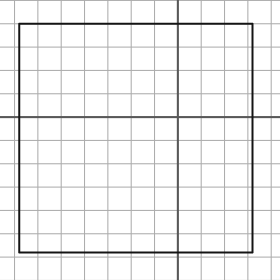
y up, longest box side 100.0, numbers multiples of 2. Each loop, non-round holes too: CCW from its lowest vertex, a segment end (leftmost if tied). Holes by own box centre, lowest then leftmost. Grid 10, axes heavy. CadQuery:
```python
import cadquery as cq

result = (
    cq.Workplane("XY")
    .moveTo(-68.0, -58.0)
    .lineTo(32.0, -58.0)
    .lineTo(32.0, 40.0)
    .lineTo(-68.0, 40.0)
    .close()
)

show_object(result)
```